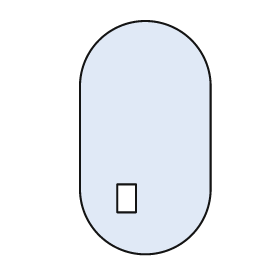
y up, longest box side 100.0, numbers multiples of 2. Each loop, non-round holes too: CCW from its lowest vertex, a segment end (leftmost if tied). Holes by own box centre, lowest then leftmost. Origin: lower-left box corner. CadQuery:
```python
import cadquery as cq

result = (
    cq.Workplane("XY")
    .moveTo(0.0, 28.0)
    .threePointArc((28.0, 0.0), (56.0, 28.0))
    .lineTo(56.0, 72.0)
    .threePointArc((28.0, 100.0), (0.0, 72.0))
    .close()
    .moveTo(16.0, 18.0)
    .lineTo(24.0, 18.0)
    .lineTo(24.0, 30.0)
    .lineTo(16.0, 30.0)
    .close()
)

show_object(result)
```